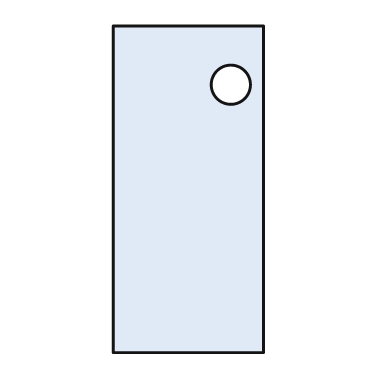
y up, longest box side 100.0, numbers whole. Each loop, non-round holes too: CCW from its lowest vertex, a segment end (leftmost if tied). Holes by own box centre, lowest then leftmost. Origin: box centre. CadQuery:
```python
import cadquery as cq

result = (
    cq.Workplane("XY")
    .moveTo(-23.0, -50.0)
    .lineTo(23.0, -50.0)
    .lineTo(23.0, 50.0)
    .lineTo(-23.0, 50.0)
    .close()
    .moveTo(13.0, 32.0)
    .circle(6.0)
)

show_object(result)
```